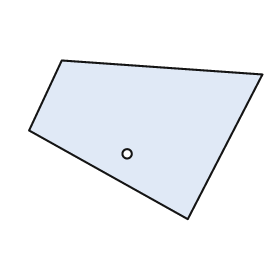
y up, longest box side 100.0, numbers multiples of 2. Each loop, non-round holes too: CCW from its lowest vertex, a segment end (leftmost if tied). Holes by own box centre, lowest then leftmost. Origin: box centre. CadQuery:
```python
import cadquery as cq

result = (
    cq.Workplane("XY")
    .moveTo(18.0, -34.0)
    .lineTo(50.0, 28.0)
    .lineTo(-36.0, 34.0)
    .lineTo(-50.0, 4.0)
    .close()
    .moveTo(-8.0, -6.0)
    .circle(2.0)
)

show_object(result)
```